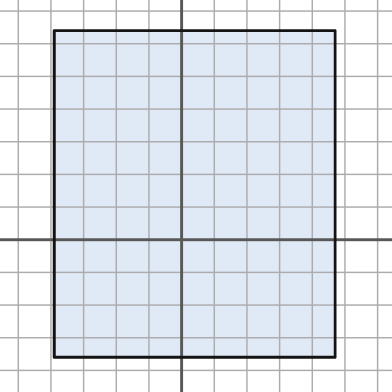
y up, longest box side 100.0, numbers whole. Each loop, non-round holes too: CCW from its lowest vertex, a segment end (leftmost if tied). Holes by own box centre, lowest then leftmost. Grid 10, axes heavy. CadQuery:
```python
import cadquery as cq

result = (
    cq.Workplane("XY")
    .moveTo(-39.0, -36.0)
    .lineTo(47.0, -36.0)
    .lineTo(47.0, 64.0)
    .lineTo(-39.0, 64.0)
    .close()
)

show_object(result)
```